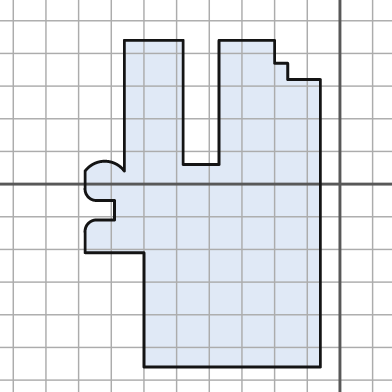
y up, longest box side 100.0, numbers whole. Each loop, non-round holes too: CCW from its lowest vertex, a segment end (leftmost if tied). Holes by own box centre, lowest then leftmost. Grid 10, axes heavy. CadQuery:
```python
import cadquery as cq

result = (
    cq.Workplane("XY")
    .moveTo(-60.0, -56.0)
    .lineTo(-6.0, -56.0)
    .lineTo(-6.0, 32.0)
    .lineTo(-16.0, 32.0)
    .lineTo(-16.0, 37.0)
    .lineTo(-20.0, 37.0)
    .lineTo(-20.0, 44.0)
    .lineTo(-37.0, 44.0)
    .lineTo(-37.0, 6.0)
    .lineTo(-48.0, 6.0)
    .lineTo(-48.0, 44.0)
    .lineTo(-66.0, 44.0)
    .lineTo(-66.0, 4.0)
    .threePointArc((-72.0, 7.0), (-78.0, 4.0))
    .lineTo(-78.0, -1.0)
    .threePointArc((-77.0, -4.0), (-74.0, -5.0))
    .lineTo(-69.0, -5.0)
    .lineTo(-69.0, -11.0)
    .lineTo(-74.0, -11.0)
    .threePointArc((-77.0, -12.0), (-78.0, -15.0))
    .lineTo(-78.0, -21.0)
    .lineTo(-60.0, -21.0)
    .close()
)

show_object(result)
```